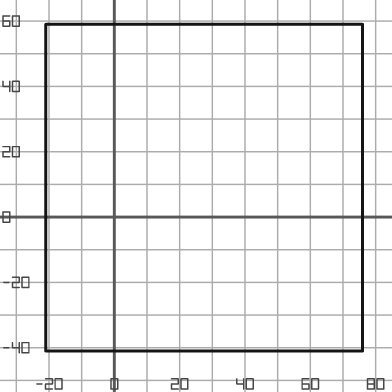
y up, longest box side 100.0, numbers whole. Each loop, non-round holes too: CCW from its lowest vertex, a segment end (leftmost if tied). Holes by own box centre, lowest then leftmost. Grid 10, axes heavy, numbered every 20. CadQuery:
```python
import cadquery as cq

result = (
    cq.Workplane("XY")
    .moveTo(-21.0, -41.0)
    .lineTo(76.0, -41.0)
    .lineTo(76.0, 59.0)
    .lineTo(-21.0, 59.0)
    .close()
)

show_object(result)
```